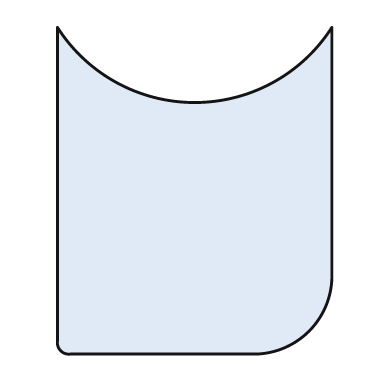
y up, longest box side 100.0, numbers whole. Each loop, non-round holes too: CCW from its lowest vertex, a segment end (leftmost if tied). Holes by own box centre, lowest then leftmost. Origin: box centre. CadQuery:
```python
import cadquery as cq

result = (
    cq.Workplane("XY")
    .moveTo(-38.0, -50.0)
    .lineTo(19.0, -50.0)
    .threePointArc((35.0, -43.0), (42.0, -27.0))
    .lineTo(42.0, 50.0)
    .threePointArc((0.0, 27.0), (-42.0, 50.0))
    .lineTo(-42.0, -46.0)
    .threePointArc((-41.0, -49.0), (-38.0, -50.0))
    .close()
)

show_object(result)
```